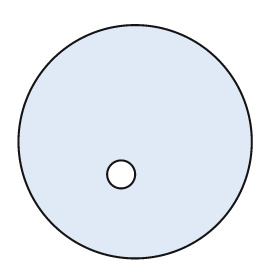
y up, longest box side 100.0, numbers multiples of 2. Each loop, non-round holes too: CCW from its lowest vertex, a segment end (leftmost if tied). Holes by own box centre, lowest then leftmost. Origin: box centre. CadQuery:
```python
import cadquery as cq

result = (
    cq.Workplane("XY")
    .moveTo(0.0, 0.0)
    .circle(50.0)
    .moveTo(-6.0, -14.0)
    .circle(6.0)
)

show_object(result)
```